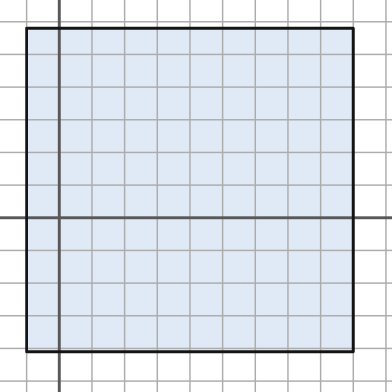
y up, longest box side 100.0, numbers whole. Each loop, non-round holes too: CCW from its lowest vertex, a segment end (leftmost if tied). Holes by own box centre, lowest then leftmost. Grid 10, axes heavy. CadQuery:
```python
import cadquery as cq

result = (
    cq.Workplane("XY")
    .moveTo(-10.0, -41.0)
    .lineTo(90.0, -41.0)
    .lineTo(90.0, 58.0)
    .lineTo(-10.0, 58.0)
    .close()
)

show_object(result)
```